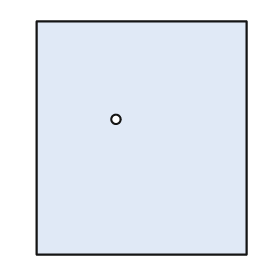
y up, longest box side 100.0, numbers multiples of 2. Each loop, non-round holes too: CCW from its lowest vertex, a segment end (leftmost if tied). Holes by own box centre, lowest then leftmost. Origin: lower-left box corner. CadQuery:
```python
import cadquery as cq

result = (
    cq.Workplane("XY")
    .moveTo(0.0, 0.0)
    .lineTo(90.0, 0.0)
    .lineTo(90.0, 100.0)
    .lineTo(0.0, 100.0)
    .close()
    .moveTo(34.0, 58.0)
    .circle(2.0)
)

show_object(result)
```